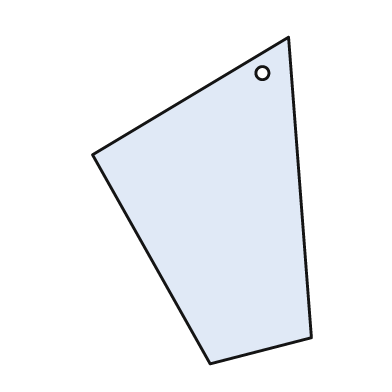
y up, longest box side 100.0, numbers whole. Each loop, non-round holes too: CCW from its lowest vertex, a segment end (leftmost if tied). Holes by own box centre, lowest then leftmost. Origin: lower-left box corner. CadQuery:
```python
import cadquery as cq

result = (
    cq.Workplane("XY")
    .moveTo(36.0, 0.0)
    .lineTo(67.0, 8.0)
    .lineTo(60.0, 100.0)
    .lineTo(0.0, 64.0)
    .close()
    .moveTo(52.0, 89.0)
    .circle(2.0)
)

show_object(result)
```